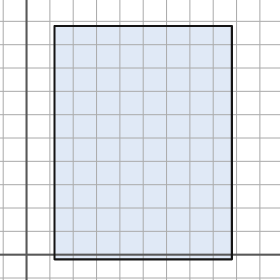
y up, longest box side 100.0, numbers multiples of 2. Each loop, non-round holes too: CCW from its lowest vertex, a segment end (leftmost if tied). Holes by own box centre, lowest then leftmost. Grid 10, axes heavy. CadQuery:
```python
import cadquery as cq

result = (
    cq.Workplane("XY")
    .moveTo(12.0, -2.0)
    .lineTo(88.0, -2.0)
    .lineTo(88.0, 98.0)
    .lineTo(12.0, 98.0)
    .close()
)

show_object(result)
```